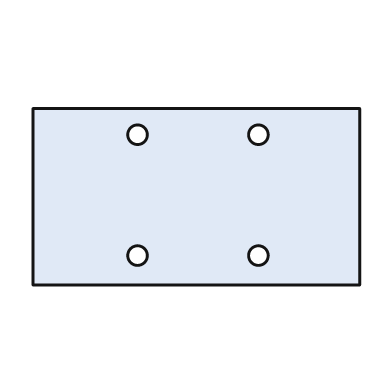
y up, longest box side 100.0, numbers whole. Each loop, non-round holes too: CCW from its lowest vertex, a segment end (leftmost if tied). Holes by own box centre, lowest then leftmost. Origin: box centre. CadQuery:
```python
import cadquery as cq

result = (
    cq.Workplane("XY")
    .moveTo(-50.0, -27.0)
    .lineTo(50.0, -27.0)
    .lineTo(50.0, 27.0)
    .lineTo(-50.0, 27.0)
    .close()
    .moveTo(-18.0, -18.0)
    .circle(3.0)
    .moveTo(19.0, -18.0)
    .circle(3.0)
    .moveTo(-18.0, 19.0)
    .circle(3.0)
    .moveTo(19.0, 19.0)
    .circle(3.0)
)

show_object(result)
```